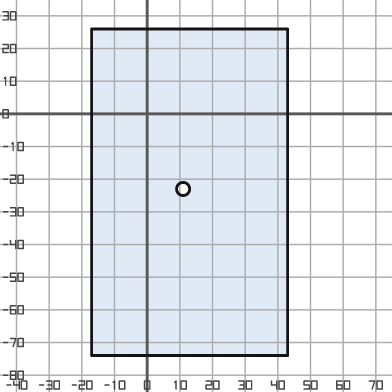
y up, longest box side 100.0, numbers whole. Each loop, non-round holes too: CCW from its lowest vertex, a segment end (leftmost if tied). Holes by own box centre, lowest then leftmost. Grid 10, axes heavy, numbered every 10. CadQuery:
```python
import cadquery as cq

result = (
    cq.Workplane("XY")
    .moveTo(-17.0, -74.0)
    .lineTo(43.0, -74.0)
    .lineTo(43.0, 26.0)
    .lineTo(-17.0, 26.0)
    .close()
    .moveTo(11.0, -23.0)
    .circle(2.0)
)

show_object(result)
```